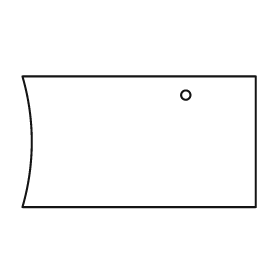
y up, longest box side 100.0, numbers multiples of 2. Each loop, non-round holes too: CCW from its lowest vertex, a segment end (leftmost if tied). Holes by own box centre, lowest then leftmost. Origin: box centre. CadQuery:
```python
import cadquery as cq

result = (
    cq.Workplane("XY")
    .moveTo(-50.0, -28.0)
    .lineTo(50.0, -28.0)
    .lineTo(50.0, 28.0)
    .lineTo(-50.0, 28.0)
    .threePointArc((-46.0, 0.0), (-50.0, -28.0))
    .close()
    .moveTo(20.0, 20.0)
    .circle(2.0)
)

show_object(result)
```